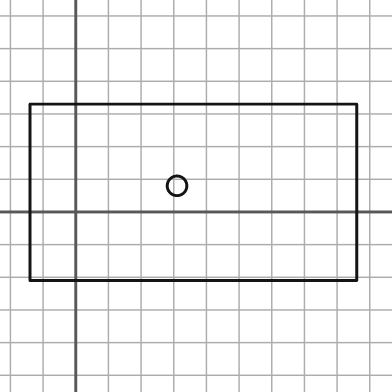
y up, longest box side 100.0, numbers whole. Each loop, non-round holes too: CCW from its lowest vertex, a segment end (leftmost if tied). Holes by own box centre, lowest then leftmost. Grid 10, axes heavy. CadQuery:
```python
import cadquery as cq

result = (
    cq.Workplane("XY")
    .moveTo(-14.0, -21.0)
    .lineTo(86.0, -21.0)
    .lineTo(86.0, 33.0)
    .lineTo(-14.0, 33.0)
    .close()
    .moveTo(31.0, 8.0)
    .circle(3.0)
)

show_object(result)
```